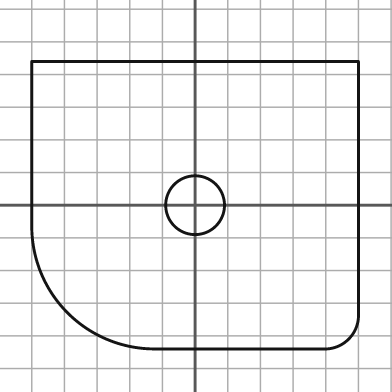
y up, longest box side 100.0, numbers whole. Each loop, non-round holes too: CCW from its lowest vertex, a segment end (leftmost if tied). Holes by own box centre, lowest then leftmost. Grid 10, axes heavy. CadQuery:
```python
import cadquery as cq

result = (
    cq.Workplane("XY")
    .moveTo(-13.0, -44.0)
    .lineTo(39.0, -44.0)
    .threePointArc((47.0, -41.0), (50.0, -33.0))
    .lineTo(50.0, 44.0)
    .lineTo(-50.0, 44.0)
    .lineTo(-50.0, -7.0)
    .threePointArc((-39.0, -33.0), (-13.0, -44.0))
    .close()
    .moveTo(0.0, 0.0)
    .circle(9.0)
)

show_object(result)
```